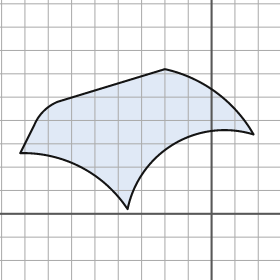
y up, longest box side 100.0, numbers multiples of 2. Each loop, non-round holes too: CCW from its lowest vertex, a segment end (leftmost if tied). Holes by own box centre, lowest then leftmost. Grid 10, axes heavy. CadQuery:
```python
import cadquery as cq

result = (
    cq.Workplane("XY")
    .moveTo(-36.0, 2.0)
    .threePointArc((-16.0, 30.0), (18.0, 34.0))
    .threePointArc((2.0, 52.0), (-20.0, 62.0))
    .lineTo(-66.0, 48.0)
    .threePointArc((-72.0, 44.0), (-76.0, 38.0))
    .lineTo(-82.0, 26.0)
    .threePointArc((-56.0, 20.0), (-36.0, 2.0))
    .close()
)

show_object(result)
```